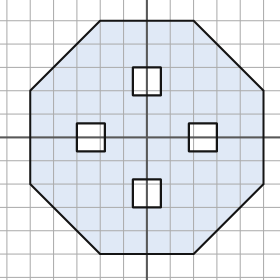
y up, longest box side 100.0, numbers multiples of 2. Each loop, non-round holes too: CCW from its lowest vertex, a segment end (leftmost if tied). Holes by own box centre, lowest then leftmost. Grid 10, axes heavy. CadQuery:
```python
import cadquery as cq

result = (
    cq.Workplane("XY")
    .moveTo(-20.0, -50.0)
    .lineTo(20.0, -50.0)
    .lineTo(50.0, -20.0)
    .lineTo(50.0, 20.0)
    .lineTo(20.0, 50.0)
    .lineTo(-20.0, 50.0)
    .lineTo(-50.0, 20.0)
    .lineTo(-50.0, -20.0)
    .close()
    .moveTo(-6.0, -30.0)
    .lineTo(6.0, -30.0)
    .lineTo(6.0, -18.0)
    .lineTo(-6.0, -18.0)
    .close()
    .moveTo(-30.0, -6.0)
    .lineTo(-18.0, -6.0)
    .lineTo(-18.0, 6.0)
    .lineTo(-30.0, 6.0)
    .close()
    .moveTo(18.0, -6.0)
    .lineTo(30.0, -6.0)
    .lineTo(30.0, 6.0)
    .lineTo(18.0, 6.0)
    .close()
    .moveTo(-6.0, 18.0)
    .lineTo(6.0, 18.0)
    .lineTo(6.0, 30.0)
    .lineTo(-6.0, 30.0)
    .close()
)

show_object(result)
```